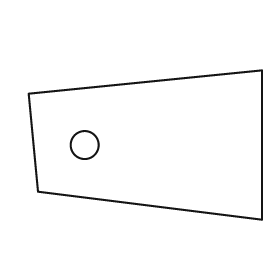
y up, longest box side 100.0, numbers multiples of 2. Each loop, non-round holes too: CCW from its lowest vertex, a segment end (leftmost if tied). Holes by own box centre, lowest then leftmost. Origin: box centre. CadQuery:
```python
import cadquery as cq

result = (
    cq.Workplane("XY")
    .moveTo(50.0, -32.0)
    .lineTo(50.0, 32.0)
    .lineTo(-50.0, 22.0)
    .lineTo(-46.0, -20.0)
    .close()
    .moveTo(-26.0, 0.0)
    .circle(6.0)
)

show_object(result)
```